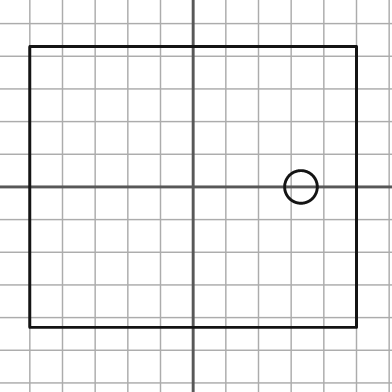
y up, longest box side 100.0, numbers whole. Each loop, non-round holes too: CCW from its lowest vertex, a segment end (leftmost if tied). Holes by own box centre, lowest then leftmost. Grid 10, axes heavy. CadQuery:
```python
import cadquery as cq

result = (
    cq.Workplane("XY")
    .moveTo(-50.0, -43.0)
    .lineTo(50.0, -43.0)
    .lineTo(50.0, 43.0)
    .lineTo(-50.0, 43.0)
    .close()
    .moveTo(33.0, 0.0)
    .circle(5.0)
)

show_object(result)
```